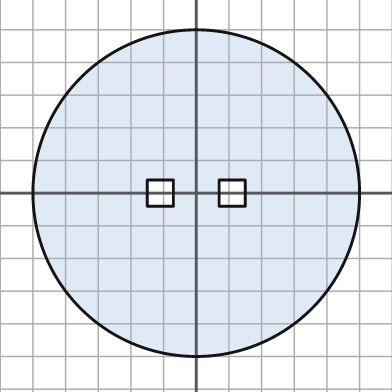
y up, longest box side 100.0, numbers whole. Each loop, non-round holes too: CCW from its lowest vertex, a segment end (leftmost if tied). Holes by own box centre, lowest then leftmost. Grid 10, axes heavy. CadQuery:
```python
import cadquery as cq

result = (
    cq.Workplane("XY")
    .moveTo(0.0, 0.0)
    .circle(50.0)
    .moveTo(-15.0, -4.0)
    .lineTo(-7.0, -4.0)
    .lineTo(-7.0, 4.0)
    .lineTo(-15.0, 4.0)
    .close()
    .moveTo(7.0, -4.0)
    .lineTo(15.0, -4.0)
    .lineTo(15.0, 4.0)
    .lineTo(7.0, 4.0)
    .close()
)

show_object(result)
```